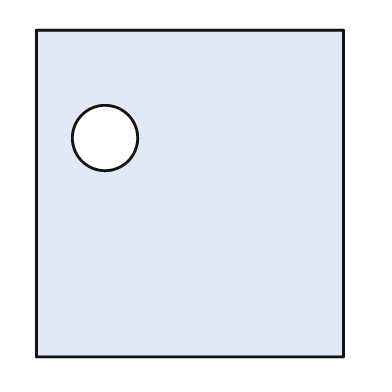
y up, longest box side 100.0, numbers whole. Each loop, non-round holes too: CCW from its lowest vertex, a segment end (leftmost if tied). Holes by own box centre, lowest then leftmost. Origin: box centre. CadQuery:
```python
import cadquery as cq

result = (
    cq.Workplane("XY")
    .moveTo(-47.0, -50.0)
    .lineTo(47.0, -50.0)
    .lineTo(47.0, 50.0)
    .lineTo(-47.0, 50.0)
    .close()
    .moveTo(-26.0, 17.0)
    .circle(10.0)
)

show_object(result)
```